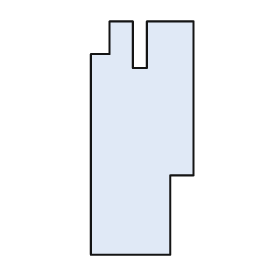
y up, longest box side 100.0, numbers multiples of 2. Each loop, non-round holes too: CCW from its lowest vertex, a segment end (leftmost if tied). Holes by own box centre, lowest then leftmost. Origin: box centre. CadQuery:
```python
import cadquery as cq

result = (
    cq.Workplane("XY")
    .moveTo(-22.0, -50.0)
    .lineTo(12.0, -50.0)
    .lineTo(12.0, -16.0)
    .lineTo(22.0, -16.0)
    .lineTo(22.0, 50.0)
    .lineTo(2.0, 50.0)
    .lineTo(2.0, 30.0)
    .lineTo(-4.0, 30.0)
    .lineTo(-4.0, 50.0)
    .lineTo(-14.0, 50.0)
    .lineTo(-14.0, 36.0)
    .lineTo(-22.0, 36.0)
    .close()
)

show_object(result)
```